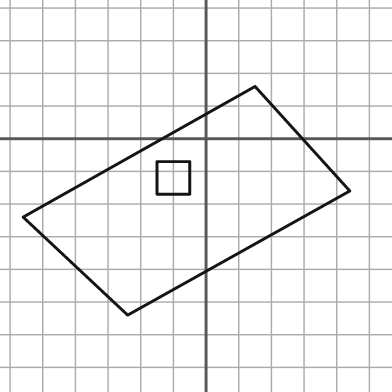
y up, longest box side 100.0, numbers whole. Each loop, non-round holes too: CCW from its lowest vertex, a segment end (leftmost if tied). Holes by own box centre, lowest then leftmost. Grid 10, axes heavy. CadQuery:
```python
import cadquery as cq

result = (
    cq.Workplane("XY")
    .moveTo(-24.0, -54.0)
    .lineTo(44.0, -16.0)
    .lineTo(15.0, 16.0)
    .lineTo(-56.0, -24.0)
    .close()
    .moveTo(-15.0, -17.0)
    .lineTo(-5.0, -17.0)
    .lineTo(-5.0, -7.0)
    .lineTo(-15.0, -7.0)
    .close()
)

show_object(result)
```